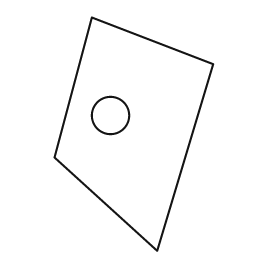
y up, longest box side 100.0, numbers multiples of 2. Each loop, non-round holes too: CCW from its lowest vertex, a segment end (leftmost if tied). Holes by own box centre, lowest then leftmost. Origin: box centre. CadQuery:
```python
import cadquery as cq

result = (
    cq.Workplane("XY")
    .moveTo(10.0, -50.0)
    .lineTo(34.0, 30.0)
    .lineTo(-18.0, 50.0)
    .lineTo(-34.0, -10.0)
    .close()
    .moveTo(-10.0, 8.0)
    .circle(8.0)
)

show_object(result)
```